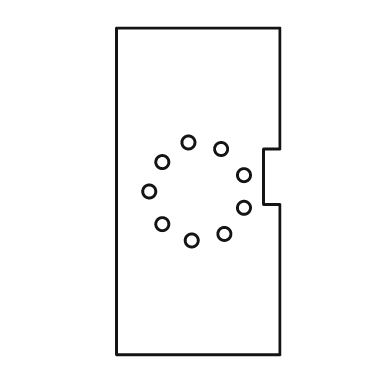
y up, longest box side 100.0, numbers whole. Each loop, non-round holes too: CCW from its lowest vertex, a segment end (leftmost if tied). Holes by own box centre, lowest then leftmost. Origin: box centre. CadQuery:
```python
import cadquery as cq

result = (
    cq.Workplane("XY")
    .moveTo(-25.0, -50.0)
    .lineTo(25.0, -50.0)
    .lineTo(25.0, -4.0)
    .lineTo(20.0, -4.0)
    .lineTo(20.0, 13.0)
    .lineTo(25.0, 13.0)
    .lineTo(25.0, 50.0)
    .lineTo(-25.0, 50.0)
    .close()
    .moveTo(-2.0, -15.0)
    .circle(2.0)
    .moveTo(8.0, -13.0)
    .circle(2.0)
    .moveTo(-11.0, -10.0)
    .circle(2.0)
    .moveTo(14.0, -5.0)
    .circle(2.0)
    .moveTo(-15.0, 0.0)
    .circle(2.0)
    .moveTo(14.0, 5.0)
    .circle(2.0)
    .moveTo(-11.0, 9.0)
    .circle(2.0)
    .moveTo(7.0, 13.0)
    .circle(2.0)
    .moveTo(-3.0, 15.0)
    .circle(2.0)
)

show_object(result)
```